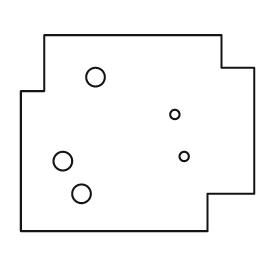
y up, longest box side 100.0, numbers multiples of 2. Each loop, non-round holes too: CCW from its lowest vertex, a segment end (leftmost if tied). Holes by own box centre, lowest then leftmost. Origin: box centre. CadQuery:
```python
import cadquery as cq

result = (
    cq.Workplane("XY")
    .moveTo(-50.0, -42.0)
    .lineTo(30.0, -42.0)
    .lineTo(30.0, -26.0)
    .lineTo(50.0, -26.0)
    .lineTo(50.0, 28.0)
    .lineTo(36.0, 28.0)
    .lineTo(36.0, 42.0)
    .lineTo(-40.0, 42.0)
    .lineTo(-40.0, 18.0)
    .lineTo(-50.0, 18.0)
    .close()
    .moveTo(-24.0, -26.0)
    .circle(4.0)
    .moveTo(-32.0, -12.0)
    .circle(4.0)
    .moveTo(20.0, -10.0)
    .circle(2.0)
    .moveTo(16.0, 8.0)
    .circle(2.0)
    .moveTo(-18.0, 24.0)
    .circle(4.0)
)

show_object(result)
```